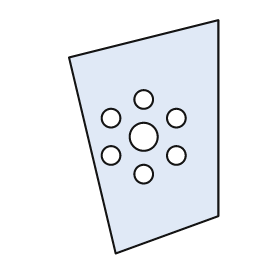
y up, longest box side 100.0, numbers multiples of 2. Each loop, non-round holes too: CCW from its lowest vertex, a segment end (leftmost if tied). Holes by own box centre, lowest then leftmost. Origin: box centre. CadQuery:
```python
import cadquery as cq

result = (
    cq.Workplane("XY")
    .moveTo(-12.0, -50.0)
    .lineTo(32.0, -34.0)
    .lineTo(32.0, 50.0)
    .lineTo(-32.0, 34.0)
    .close()
    .moveTo(0.0, -16.0)
    .circle(4.0)
    .moveTo(-14.0, -8.0)
    .circle(4.0)
    .moveTo(14.0, -8.0)
    .circle(4.0)
    .moveTo(0.0, 0.0)
    .circle(6.0)
    .moveTo(-14.0, 8.0)
    .circle(4.0)
    .moveTo(14.0, 8.0)
    .circle(4.0)
    .moveTo(0.0, 16.0)
    .circle(4.0)
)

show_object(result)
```